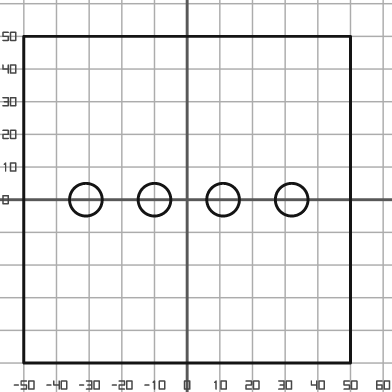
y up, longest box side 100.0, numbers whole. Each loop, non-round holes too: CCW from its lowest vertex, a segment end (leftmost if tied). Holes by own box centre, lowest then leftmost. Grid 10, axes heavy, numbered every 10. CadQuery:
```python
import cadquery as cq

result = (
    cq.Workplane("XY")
    .moveTo(-50.0, -50.0)
    .lineTo(50.0, -50.0)
    .lineTo(50.0, 50.0)
    .lineTo(-50.0, 50.0)
    .close()
    .moveTo(-31.0, 0.0)
    .circle(5.0)
    .moveTo(-10.0, 0.0)
    .circle(5.0)
    .moveTo(11.0, 0.0)
    .circle(5.0)
    .moveTo(32.0, 0.0)
    .circle(5.0)
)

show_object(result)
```